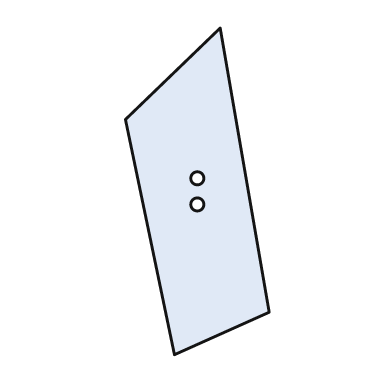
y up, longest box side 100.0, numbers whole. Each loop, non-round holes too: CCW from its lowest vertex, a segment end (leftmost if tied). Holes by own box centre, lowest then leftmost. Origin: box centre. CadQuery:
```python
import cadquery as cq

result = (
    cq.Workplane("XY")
    .moveTo(-7.0, -50.0)
    .lineTo(22.0, -37.0)
    .lineTo(7.0, 50.0)
    .lineTo(-22.0, 22.0)
    .close()
    .moveTo(0.0, -4.0)
    .circle(2.0)
    .moveTo(0.0, 4.0)
    .circle(2.0)
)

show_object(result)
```